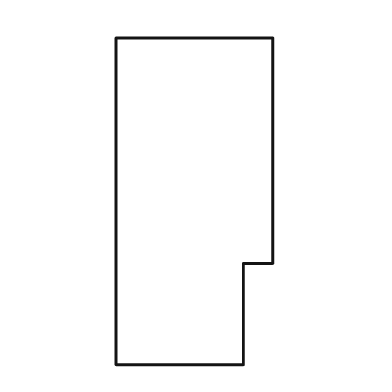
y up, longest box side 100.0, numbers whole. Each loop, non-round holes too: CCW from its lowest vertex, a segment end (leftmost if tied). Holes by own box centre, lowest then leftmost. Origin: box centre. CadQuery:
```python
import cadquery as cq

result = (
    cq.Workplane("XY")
    .moveTo(-24.0, -50.0)
    .lineTo(15.0, -50.0)
    .lineTo(15.0, -19.0)
    .lineTo(24.0, -19.0)
    .lineTo(24.0, 50.0)
    .lineTo(-24.0, 50.0)
    .close()
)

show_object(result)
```